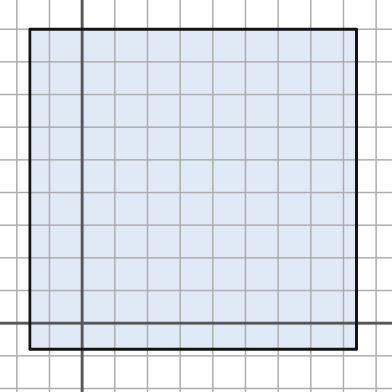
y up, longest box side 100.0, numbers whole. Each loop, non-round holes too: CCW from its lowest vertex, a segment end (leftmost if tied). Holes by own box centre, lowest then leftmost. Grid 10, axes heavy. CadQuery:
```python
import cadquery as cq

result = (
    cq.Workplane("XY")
    .moveTo(-16.0, -8.0)
    .lineTo(84.0, -8.0)
    .lineTo(84.0, 90.0)
    .lineTo(-16.0, 90.0)
    .close()
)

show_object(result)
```